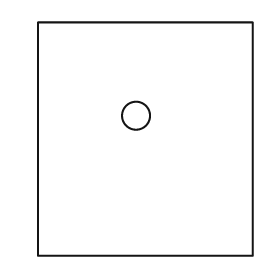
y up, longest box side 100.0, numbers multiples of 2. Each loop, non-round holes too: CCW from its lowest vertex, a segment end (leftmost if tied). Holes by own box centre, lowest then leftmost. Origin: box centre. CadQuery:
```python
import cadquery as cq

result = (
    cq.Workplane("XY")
    .moveTo(-46.0, -50.0)
    .lineTo(46.0, -50.0)
    .lineTo(46.0, 50.0)
    .lineTo(-46.0, 50.0)
    .close()
    .moveTo(-4.0, 10.0)
    .circle(6.0)
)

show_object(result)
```